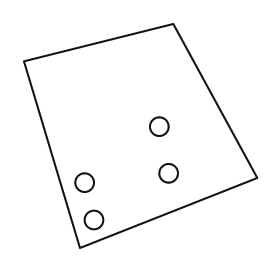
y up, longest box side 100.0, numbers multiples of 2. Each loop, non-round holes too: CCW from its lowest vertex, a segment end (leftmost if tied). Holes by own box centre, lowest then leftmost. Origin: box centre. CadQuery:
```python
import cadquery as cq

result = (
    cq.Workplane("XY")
    .moveTo(-26.0, -48.0)
    .lineTo(50.0, -18.0)
    .lineTo(14.0, 48.0)
    .lineTo(-50.0, 32.0)
    .close()
    .moveTo(-20.0, -36.0)
    .circle(4.0)
    .moveTo(-24.0, -20.0)
    .circle(4.0)
    .moveTo(12.0, -16.0)
    .circle(4.0)
    .moveTo(8.0, 4.0)
    .circle(4.0)
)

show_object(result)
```